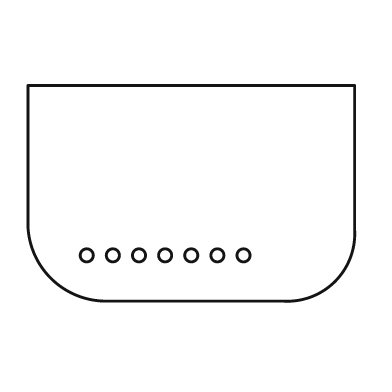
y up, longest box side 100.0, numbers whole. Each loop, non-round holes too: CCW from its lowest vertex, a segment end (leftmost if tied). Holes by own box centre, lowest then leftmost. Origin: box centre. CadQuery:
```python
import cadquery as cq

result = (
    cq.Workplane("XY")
    .moveTo(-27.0, -33.0)
    .lineTo(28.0, -33.0)
    .threePointArc((44.0, -27.0), (50.0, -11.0))
    .lineTo(50.0, 33.0)
    .lineTo(-50.0, 33.0)
    .lineTo(-50.0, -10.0)
    .threePointArc((-43.0, -26.0), (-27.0, -33.0))
    .close()
    .moveTo(-32.0, -19.0)
    .circle(2.0)
    .moveTo(-24.0, -19.0)
    .circle(2.0)
    .moveTo(-16.0, -19.0)
    .circle(2.0)
    .moveTo(-8.0, -19.0)
    .circle(2.0)
    .moveTo(0.0, -19.0)
    .circle(2.0)
    .moveTo(8.0, -19.0)
    .circle(2.0)
    .moveTo(16.0, -19.0)
    .circle(2.0)
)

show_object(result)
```